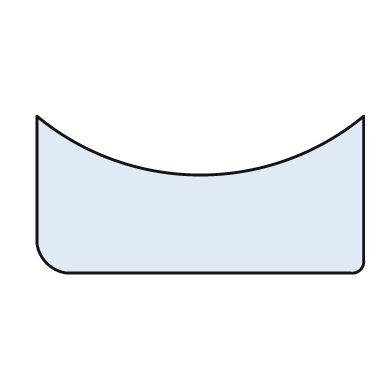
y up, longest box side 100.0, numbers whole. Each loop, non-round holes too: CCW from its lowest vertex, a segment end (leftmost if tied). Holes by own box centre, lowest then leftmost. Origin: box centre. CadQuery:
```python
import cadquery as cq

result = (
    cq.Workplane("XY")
    .moveTo(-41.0, -24.0)
    .lineTo(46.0, -24.0)
    .threePointArc((49.0, -23.0), (50.0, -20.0))
    .lineTo(50.0, 24.0)
    .threePointArc((0.0, 6.0), (-50.0, 24.0))
    .lineTo(-50.0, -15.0)
    .threePointArc((-47.0, -21.0), (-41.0, -24.0))
    .close()
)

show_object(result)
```